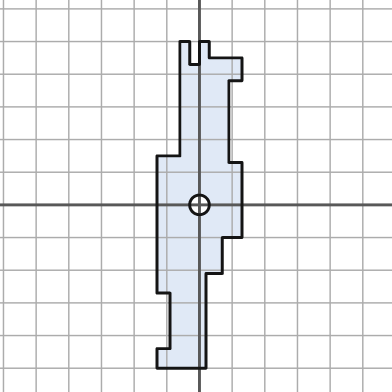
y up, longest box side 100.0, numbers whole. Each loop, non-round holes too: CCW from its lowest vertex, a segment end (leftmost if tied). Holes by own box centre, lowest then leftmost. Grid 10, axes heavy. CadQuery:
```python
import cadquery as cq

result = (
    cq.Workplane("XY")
    .moveTo(-13.0, -50.0)
    .lineTo(2.0, -50.0)
    .lineTo(2.0, -21.0)
    .lineTo(7.0, -21.0)
    .lineTo(7.0, -10.0)
    .lineTo(13.0, -10.0)
    .lineTo(13.0, 13.0)
    .lineTo(9.0, 13.0)
    .lineTo(9.0, 38.0)
    .lineTo(13.0, 38.0)
    .lineTo(13.0, 45.0)
    .lineTo(3.0, 45.0)
    .lineTo(3.0, 50.0)
    .lineTo(0.0, 50.0)
    .lineTo(0.0, 43.0)
    .lineTo(-3.0, 43.0)
    .lineTo(-3.0, 50.0)
    .lineTo(-6.0, 50.0)
    .lineTo(-6.0, 15.0)
    .lineTo(-13.0, 15.0)
    .lineTo(-13.0, -27.0)
    .lineTo(-9.0, -27.0)
    .lineTo(-9.0, -44.0)
    .lineTo(-13.0, -44.0)
    .close()
    .moveTo(0.0, 0.0)
    .circle(3.0)
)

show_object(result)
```